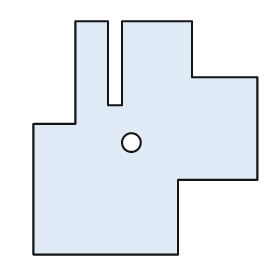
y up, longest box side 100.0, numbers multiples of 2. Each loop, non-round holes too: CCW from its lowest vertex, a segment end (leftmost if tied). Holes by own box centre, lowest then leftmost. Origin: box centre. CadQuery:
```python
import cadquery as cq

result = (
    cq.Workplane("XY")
    .moveTo(-48.0, -50.0)
    .lineTo(14.0, -50.0)
    .lineTo(14.0, -18.0)
    .lineTo(48.0, -18.0)
    .lineTo(48.0, 26.0)
    .lineTo(20.0, 26.0)
    .lineTo(20.0, 50.0)
    .lineTo(-10.0, 50.0)
    .lineTo(-10.0, 14.0)
    .lineTo(-16.0, 14.0)
    .lineTo(-16.0, 50.0)
    .lineTo(-30.0, 50.0)
    .lineTo(-30.0, 6.0)
    .lineTo(-48.0, 6.0)
    .close()
    .moveTo(-6.0, -2.0)
    .circle(4.0)
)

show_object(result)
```